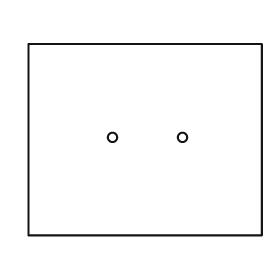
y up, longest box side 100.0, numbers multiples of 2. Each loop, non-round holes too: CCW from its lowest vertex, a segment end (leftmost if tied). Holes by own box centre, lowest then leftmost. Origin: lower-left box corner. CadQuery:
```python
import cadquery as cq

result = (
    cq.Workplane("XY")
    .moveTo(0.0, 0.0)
    .lineTo(100.0, 0.0)
    .lineTo(100.0, 82.0)
    .lineTo(0.0, 82.0)
    .close()
    .moveTo(36.0, 42.0)
    .circle(2.0)
    .moveTo(66.0, 42.0)
    .circle(2.0)
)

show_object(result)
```